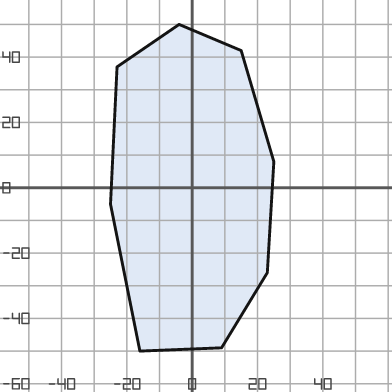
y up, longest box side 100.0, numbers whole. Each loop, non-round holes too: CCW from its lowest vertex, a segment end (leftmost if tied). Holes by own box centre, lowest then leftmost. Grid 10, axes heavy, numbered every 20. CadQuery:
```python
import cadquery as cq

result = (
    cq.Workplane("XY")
    .moveTo(-16.0, -50.0)
    .lineTo(9.0, -49.0)
    .lineTo(23.0, -26.0)
    .lineTo(25.0, 8.0)
    .lineTo(15.0, 42.0)
    .lineTo(-4.0, 50.0)
    .lineTo(-23.0, 37.0)
    .lineTo(-25.0, -5.0)
    .close()
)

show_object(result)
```